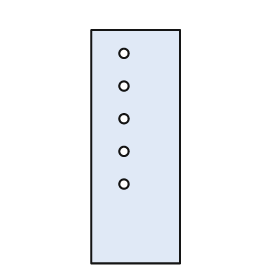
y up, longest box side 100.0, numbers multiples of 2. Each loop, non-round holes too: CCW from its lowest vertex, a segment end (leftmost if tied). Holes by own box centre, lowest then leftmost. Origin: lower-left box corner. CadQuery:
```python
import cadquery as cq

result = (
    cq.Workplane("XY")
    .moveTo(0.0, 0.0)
    .lineTo(38.0, 0.0)
    .lineTo(38.0, 100.0)
    .lineTo(0.0, 100.0)
    .close()
    .moveTo(14.0, 34.0)
    .circle(2.0)
    .moveTo(14.0, 48.0)
    .circle(2.0)
    .moveTo(14.0, 62.0)
    .circle(2.0)
    .moveTo(14.0, 76.0)
    .circle(2.0)
    .moveTo(14.0, 90.0)
    .circle(2.0)
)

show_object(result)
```